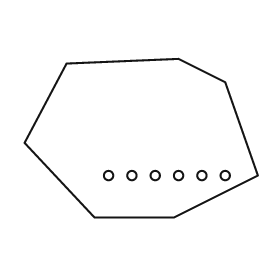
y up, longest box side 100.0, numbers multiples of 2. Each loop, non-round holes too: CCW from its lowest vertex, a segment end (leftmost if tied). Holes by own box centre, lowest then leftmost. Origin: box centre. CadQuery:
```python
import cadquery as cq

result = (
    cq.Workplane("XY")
    .moveTo(-20.0, -34.0)
    .lineTo(14.0, -34.0)
    .lineTo(50.0, -16.0)
    .lineTo(36.0, 24.0)
    .lineTo(16.0, 34.0)
    .lineTo(-32.0, 32.0)
    .lineTo(-50.0, -2.0)
    .close()
    .moveTo(-14.0, -16.0)
    .circle(2.0)
    .moveTo(-4.0, -16.0)
    .circle(2.0)
    .moveTo(6.0, -16.0)
    .circle(2.0)
    .moveTo(16.0, -16.0)
    .circle(2.0)
    .moveTo(26.0, -16.0)
    .circle(2.0)
    .moveTo(36.0, -16.0)
    .circle(2.0)
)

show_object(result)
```